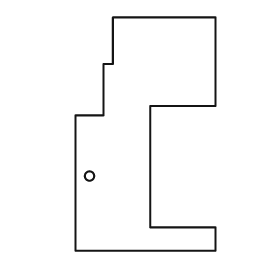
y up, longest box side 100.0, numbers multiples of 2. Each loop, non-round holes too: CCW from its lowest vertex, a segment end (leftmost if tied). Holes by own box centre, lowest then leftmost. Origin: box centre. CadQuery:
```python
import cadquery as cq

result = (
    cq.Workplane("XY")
    .moveTo(-30.0, -50.0)
    .lineTo(30.0, -50.0)
    .lineTo(30.0, -40.0)
    .lineTo(2.0, -40.0)
    .lineTo(2.0, 12.0)
    .lineTo(30.0, 12.0)
    .lineTo(30.0, 50.0)
    .lineTo(-14.0, 50.0)
    .lineTo(-14.0, 30.0)
    .lineTo(-18.0, 30.0)
    .lineTo(-18.0, 8.0)
    .lineTo(-30.0, 8.0)
    .close()
    .moveTo(-24.0, -18.0)
    .circle(2.0)
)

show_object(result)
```